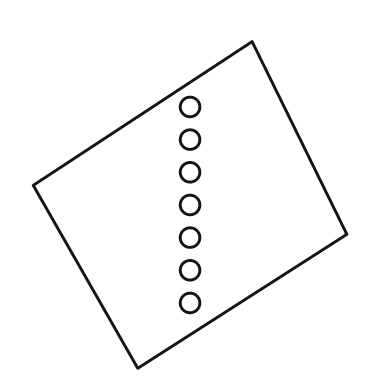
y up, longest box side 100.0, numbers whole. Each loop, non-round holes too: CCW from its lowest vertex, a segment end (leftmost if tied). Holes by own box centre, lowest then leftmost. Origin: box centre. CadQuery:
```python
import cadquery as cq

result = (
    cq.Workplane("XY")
    .moveTo(-16.0, -50.0)
    .lineTo(48.0, -9.0)
    .lineTo(19.0, 50.0)
    .lineTo(-48.0, 6.0)
    .close()
    .moveTo(0.0, -30.0)
    .circle(3.0)
    .moveTo(0.0, -20.0)
    .circle(3.0)
    .moveTo(0.0, -10.0)
    .circle(3.0)
    .moveTo(0.0, 0.0)
    .circle(3.0)
    .moveTo(0.0, 10.0)
    .circle(3.0)
    .moveTo(0.0, 20.0)
    .circle(3.0)
    .moveTo(0.0, 30.0)
    .circle(3.0)
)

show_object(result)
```